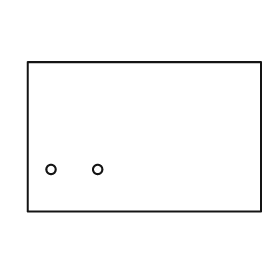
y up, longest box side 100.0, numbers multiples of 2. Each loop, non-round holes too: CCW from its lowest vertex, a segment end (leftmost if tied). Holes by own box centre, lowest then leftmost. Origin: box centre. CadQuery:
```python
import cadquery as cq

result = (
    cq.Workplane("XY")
    .moveTo(-50.0, -32.0)
    .lineTo(50.0, -32.0)
    .lineTo(50.0, 32.0)
    .lineTo(-50.0, 32.0)
    .close()
    .moveTo(-40.0, -14.0)
    .circle(2.0)
    .moveTo(-20.0, -14.0)
    .circle(2.0)
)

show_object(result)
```